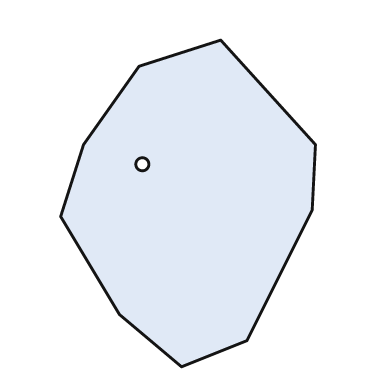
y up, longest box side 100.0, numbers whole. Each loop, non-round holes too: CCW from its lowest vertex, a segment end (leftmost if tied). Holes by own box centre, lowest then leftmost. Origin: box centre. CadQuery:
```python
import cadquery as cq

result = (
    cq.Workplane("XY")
    .moveTo(-2.0, -50.0)
    .lineTo(18.0, -42.0)
    .lineTo(38.0, -2.0)
    .lineTo(39.0, 18.0)
    .lineTo(10.0, 50.0)
    .lineTo(-15.0, 42.0)
    .lineTo(-32.0, 18.0)
    .lineTo(-39.0, -4.0)
    .lineTo(-21.0, -34.0)
    .close()
    .moveTo(-14.0, 12.0)
    .circle(2.0)
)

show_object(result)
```